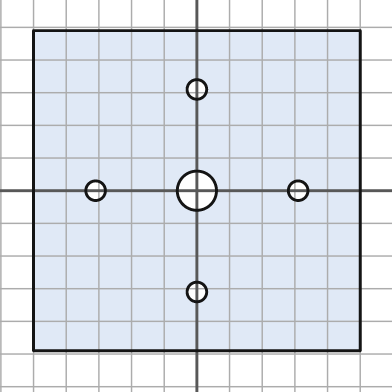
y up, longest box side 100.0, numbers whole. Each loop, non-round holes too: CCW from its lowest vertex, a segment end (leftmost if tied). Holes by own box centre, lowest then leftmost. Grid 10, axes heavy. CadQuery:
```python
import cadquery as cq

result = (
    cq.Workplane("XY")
    .moveTo(-50.0, -49.0)
    .lineTo(50.0, -49.0)
    .lineTo(50.0, 49.0)
    .lineTo(-50.0, 49.0)
    .close()
    .moveTo(0.0, -31.0)
    .circle(3.0)
    .moveTo(-31.0, 0.0)
    .circle(3.0)
    .moveTo(0.0, 0.0)
    .circle(6.0)
    .moveTo(31.0, 0.0)
    .circle(3.0)
    .moveTo(0.0, 31.0)
    .circle(3.0)
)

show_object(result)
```